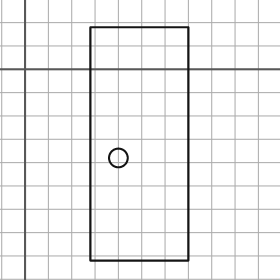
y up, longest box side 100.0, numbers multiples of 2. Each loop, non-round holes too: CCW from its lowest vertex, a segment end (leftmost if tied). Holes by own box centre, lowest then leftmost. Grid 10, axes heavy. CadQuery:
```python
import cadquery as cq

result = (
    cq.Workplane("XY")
    .moveTo(28.0, -82.0)
    .lineTo(70.0, -82.0)
    .lineTo(70.0, 18.0)
    .lineTo(28.0, 18.0)
    .close()
    .moveTo(40.0, -38.0)
    .circle(4.0)
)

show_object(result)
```